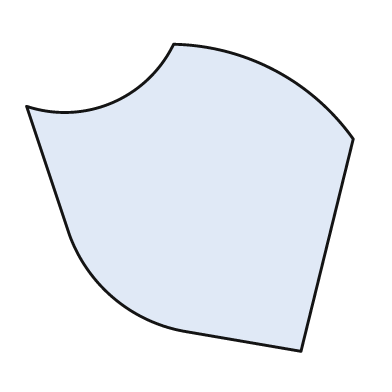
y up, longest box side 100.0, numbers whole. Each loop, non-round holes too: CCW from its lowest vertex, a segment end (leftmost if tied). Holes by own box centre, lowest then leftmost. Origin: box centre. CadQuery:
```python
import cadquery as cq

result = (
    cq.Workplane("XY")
    .moveTo(34.0, -47.0)
    .lineTo(50.0, 18.0)
    .threePointArc((26.0, 39.0), (-5.0, 47.0))
    .threePointArc((-24.0, 29.0), (-50.0, 28.0))
    .lineTo(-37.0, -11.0)
    .threePointArc((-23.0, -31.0), (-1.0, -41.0))
    .close()
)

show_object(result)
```